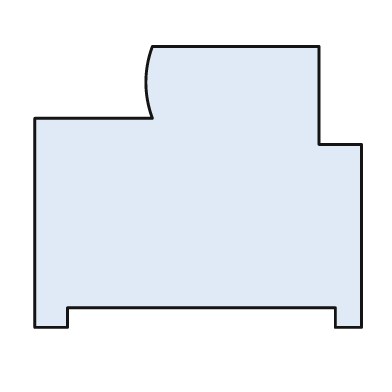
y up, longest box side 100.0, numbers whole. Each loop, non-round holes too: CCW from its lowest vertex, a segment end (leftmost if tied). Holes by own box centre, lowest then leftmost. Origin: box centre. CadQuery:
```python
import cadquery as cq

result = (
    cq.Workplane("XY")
    .moveTo(-50.0, -43.0)
    .lineTo(-40.0, -43.0)
    .lineTo(-40.0, -37.0)
    .lineTo(42.0, -37.0)
    .lineTo(42.0, -43.0)
    .lineTo(50.0, -43.0)
    .lineTo(50.0, 13.0)
    .lineTo(37.0, 13.0)
    .lineTo(37.0, 43.0)
    .lineTo(-14.0, 43.0)
    .threePointArc((-16.0, 32.0), (-14.0, 21.0))
    .lineTo(-50.0, 21.0)
    .close()
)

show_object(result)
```